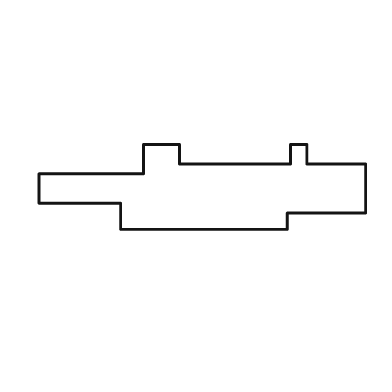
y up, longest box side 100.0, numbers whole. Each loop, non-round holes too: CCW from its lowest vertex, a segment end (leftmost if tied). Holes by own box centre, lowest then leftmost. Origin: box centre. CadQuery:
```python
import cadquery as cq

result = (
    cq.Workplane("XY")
    .moveTo(-25.0, -13.0)
    .lineTo(26.0, -13.0)
    .lineTo(26.0, -8.0)
    .lineTo(50.0, -8.0)
    .lineTo(50.0, 7.0)
    .lineTo(32.0, 7.0)
    .lineTo(32.0, 13.0)
    .lineTo(27.0, 13.0)
    .lineTo(27.0, 7.0)
    .lineTo(-7.0, 7.0)
    .lineTo(-7.0, 13.0)
    .lineTo(-18.0, 13.0)
    .lineTo(-18.0, 4.0)
    .lineTo(-50.0, 4.0)
    .lineTo(-50.0, -5.0)
    .lineTo(-25.0, -5.0)
    .close()
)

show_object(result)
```